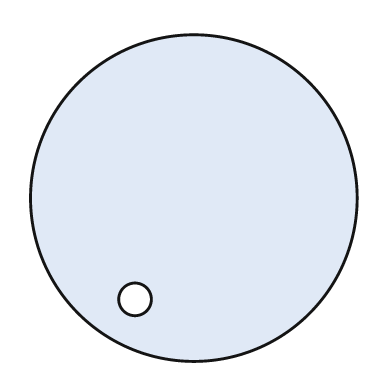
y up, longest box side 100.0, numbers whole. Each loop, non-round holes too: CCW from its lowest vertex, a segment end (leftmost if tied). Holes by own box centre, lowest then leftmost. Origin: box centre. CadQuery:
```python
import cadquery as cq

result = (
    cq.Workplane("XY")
    .moveTo(0.0, 0.0)
    .circle(50.0)
    .moveTo(-18.0, -31.0)
    .circle(5.0)
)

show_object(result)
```